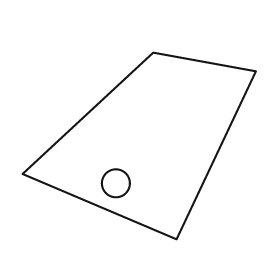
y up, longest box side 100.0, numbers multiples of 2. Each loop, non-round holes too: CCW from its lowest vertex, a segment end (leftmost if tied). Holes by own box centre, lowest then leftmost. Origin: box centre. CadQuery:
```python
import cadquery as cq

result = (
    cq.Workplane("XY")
    .moveTo(16.0, -40.0)
    .lineTo(50.0, 32.0)
    .lineTo(6.0, 40.0)
    .lineTo(-50.0, -12.0)
    .close()
    .moveTo(-10.0, -16.0)
    .circle(6.0)
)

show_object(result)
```